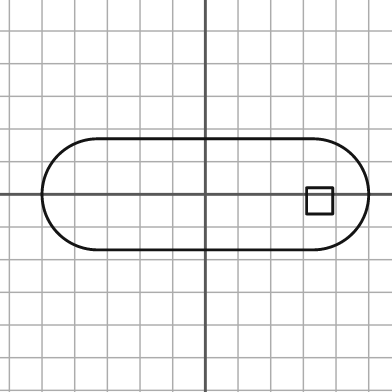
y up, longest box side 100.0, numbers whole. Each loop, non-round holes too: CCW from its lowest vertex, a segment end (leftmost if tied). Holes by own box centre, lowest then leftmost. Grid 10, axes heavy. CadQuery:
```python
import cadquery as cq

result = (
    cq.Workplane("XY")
    .moveTo(-33.0, -17.0)
    .lineTo(33.0, -17.0)
    .threePointArc((50.0, 0.0), (33.0, 17.0))
    .lineTo(-33.0, 17.0)
    .threePointArc((-50.0, 0.0), (-33.0, -17.0))
    .close()
    .moveTo(31.0, -6.0)
    .lineTo(39.0, -6.0)
    .lineTo(39.0, 2.0)
    .lineTo(31.0, 2.0)
    .close()
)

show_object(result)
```